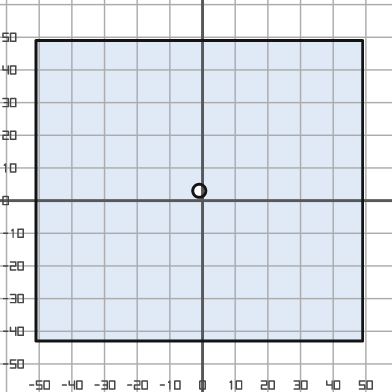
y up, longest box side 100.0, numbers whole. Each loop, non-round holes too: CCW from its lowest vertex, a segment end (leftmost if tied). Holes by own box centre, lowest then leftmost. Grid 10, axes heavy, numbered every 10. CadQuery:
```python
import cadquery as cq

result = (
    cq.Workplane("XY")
    .moveTo(-51.0, -43.0)
    .lineTo(49.0, -43.0)
    .lineTo(49.0, 49.0)
    .lineTo(-51.0, 49.0)
    .close()
    .moveTo(-1.0, 3.0)
    .circle(2.0)
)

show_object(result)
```